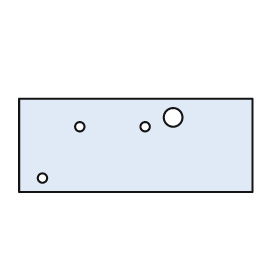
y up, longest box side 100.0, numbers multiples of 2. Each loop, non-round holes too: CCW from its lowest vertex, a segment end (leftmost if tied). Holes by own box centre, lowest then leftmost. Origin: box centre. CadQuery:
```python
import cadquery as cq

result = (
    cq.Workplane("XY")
    .moveTo(-50.0, -20.0)
    .lineTo(50.0, -20.0)
    .lineTo(50.0, 20.0)
    .lineTo(-50.0, 20.0)
    .close()
    .moveTo(-40.0, -14.0)
    .circle(2.0)
    .moveTo(-24.0, 8.0)
    .circle(2.0)
    .moveTo(4.0, 8.0)
    .circle(2.0)
    .moveTo(16.0, 12.0)
    .circle(4.0)
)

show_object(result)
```